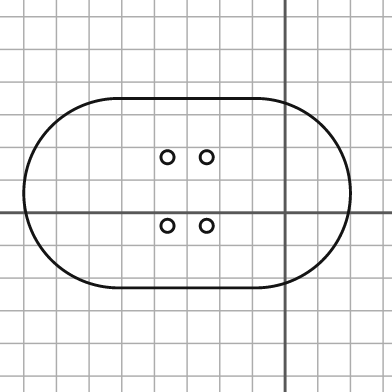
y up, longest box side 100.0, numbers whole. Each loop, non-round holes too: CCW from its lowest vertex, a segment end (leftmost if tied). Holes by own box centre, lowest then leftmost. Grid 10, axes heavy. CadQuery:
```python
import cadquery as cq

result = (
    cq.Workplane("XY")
    .moveTo(-51.0, -23.0)
    .lineTo(-9.0, -23.0)
    .threePointArc((20.0, 6.0), (-9.0, 35.0))
    .lineTo(-51.0, 35.0)
    .threePointArc((-80.0, 6.0), (-51.0, -23.0))
    .close()
    .moveTo(-36.0, -4.0)
    .circle(2.0)
    .moveTo(-24.0, -4.0)
    .circle(2.0)
    .moveTo(-36.0, 17.0)
    .circle(2.0)
    .moveTo(-24.0, 17.0)
    .circle(2.0)
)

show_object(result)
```